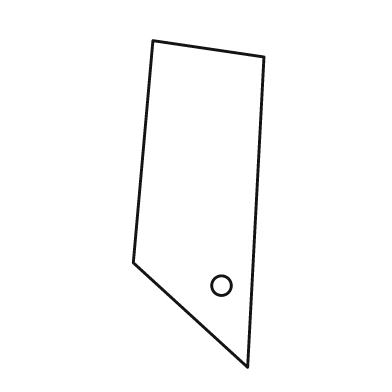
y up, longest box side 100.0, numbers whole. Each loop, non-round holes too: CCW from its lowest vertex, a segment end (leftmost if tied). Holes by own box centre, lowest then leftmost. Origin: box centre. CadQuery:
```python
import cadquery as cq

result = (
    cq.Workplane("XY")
    .moveTo(15.0, -50.0)
    .lineTo(20.0, 45.0)
    .lineTo(-14.0, 50.0)
    .lineTo(-20.0, -18.0)
    .close()
    .moveTo(7.0, -25.0)
    .circle(3.0)
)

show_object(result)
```